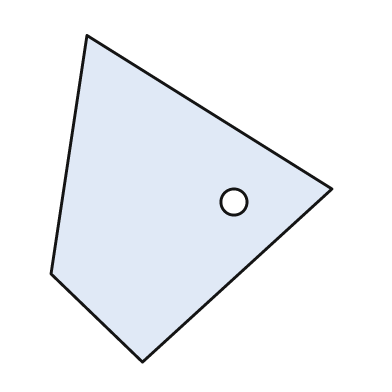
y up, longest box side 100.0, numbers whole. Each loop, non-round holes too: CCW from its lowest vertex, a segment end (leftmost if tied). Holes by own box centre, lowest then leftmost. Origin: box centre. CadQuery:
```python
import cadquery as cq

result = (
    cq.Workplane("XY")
    .moveTo(-15.0, -50.0)
    .lineTo(43.0, 3.0)
    .lineTo(-32.0, 50.0)
    .lineTo(-43.0, -23.0)
    .close()
    .moveTo(13.0, -1.0)
    .circle(4.0)
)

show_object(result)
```